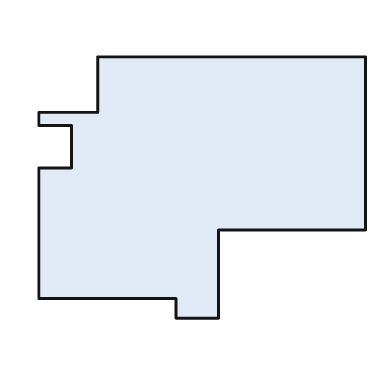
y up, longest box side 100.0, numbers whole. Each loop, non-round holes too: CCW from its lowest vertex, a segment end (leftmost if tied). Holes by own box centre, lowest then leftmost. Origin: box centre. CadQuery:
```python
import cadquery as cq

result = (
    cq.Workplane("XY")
    .moveTo(-8.0, -40.0)
    .lineTo(5.0, -40.0)
    .lineTo(5.0, -13.0)
    .lineTo(50.0, -13.0)
    .lineTo(50.0, 40.0)
    .lineTo(-32.0, 40.0)
    .lineTo(-32.0, 23.0)
    .lineTo(-50.0, 23.0)
    .lineTo(-50.0, 19.0)
    .lineTo(-40.0, 19.0)
    .lineTo(-40.0, 6.0)
    .lineTo(-50.0, 6.0)
    .lineTo(-50.0, -34.0)
    .lineTo(-8.0, -34.0)
    .close()
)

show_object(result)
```